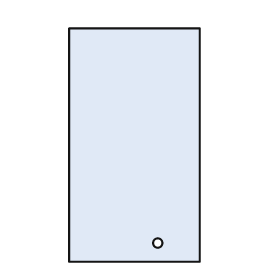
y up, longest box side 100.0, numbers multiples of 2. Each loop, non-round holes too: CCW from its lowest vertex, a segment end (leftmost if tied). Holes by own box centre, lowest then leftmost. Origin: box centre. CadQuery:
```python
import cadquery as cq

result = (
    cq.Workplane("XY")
    .moveTo(-28.0, -50.0)
    .lineTo(28.0, -50.0)
    .lineTo(28.0, 50.0)
    .lineTo(-28.0, 50.0)
    .close()
    .moveTo(10.0, -42.0)
    .circle(2.0)
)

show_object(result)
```